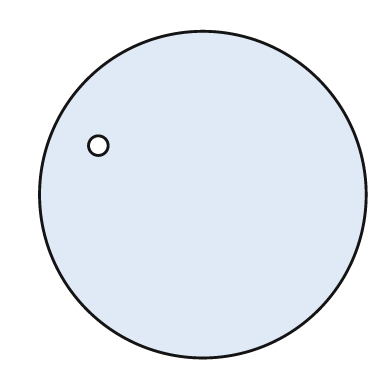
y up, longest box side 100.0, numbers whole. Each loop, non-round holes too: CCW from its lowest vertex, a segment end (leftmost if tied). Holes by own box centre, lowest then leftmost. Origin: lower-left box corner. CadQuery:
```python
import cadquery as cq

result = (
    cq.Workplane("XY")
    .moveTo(50.0, 50.0)
    .circle(50.0)
    .moveTo(18.0, 65.0)
    .circle(3.0)
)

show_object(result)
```